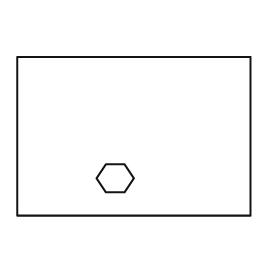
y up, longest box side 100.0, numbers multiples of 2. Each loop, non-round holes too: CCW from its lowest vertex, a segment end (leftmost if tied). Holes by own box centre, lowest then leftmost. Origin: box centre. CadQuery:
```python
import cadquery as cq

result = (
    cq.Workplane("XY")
    .moveTo(-50.0, -34.0)
    .lineTo(50.0, -34.0)
    .lineTo(50.0, 34.0)
    .lineTo(-50.0, 34.0)
    .close()
    .moveTo(-12.0, -24.0)
    .lineTo(-4.0, -24.0)
    .lineTo(0.0, -18.0)
    .lineTo(-4.0, -12.0)
    .lineTo(-12.0, -12.0)
    .lineTo(-16.0, -18.0)
    .close()
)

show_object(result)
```